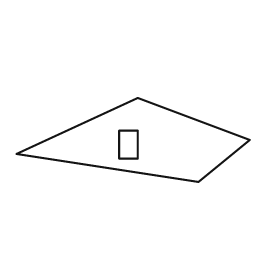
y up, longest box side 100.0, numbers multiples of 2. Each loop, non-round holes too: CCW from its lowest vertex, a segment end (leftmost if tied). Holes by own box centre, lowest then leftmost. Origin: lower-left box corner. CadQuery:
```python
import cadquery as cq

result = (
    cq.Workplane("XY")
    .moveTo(78.0, 0.0)
    .lineTo(100.0, 18.0)
    .lineTo(52.0, 36.0)
    .lineTo(0.0, 12.0)
    .close()
    .moveTo(44.0, 10.0)
    .lineTo(52.0, 10.0)
    .lineTo(52.0, 22.0)
    .lineTo(44.0, 22.0)
    .close()
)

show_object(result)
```